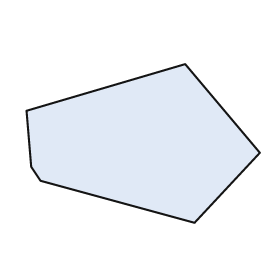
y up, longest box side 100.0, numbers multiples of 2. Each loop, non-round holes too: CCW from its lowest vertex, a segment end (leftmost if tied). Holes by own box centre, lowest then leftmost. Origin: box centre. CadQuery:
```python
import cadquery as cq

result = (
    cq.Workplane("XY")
    .moveTo(22.0, -34.0)
    .lineTo(50.0, -4.0)
    .lineTo(18.0, 34.0)
    .lineTo(-50.0, 14.0)
    .lineTo(-48.0, -10.0)
    .lineTo(-44.0, -16.0)
    .close()
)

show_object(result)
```